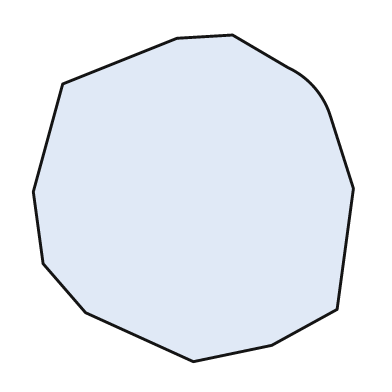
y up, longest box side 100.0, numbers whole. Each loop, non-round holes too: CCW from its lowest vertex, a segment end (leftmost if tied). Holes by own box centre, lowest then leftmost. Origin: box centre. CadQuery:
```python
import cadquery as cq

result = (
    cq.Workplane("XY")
    .moveTo(0.0, -50.0)
    .lineTo(24.0, -45.0)
    .lineTo(44.0, -34.0)
    .lineTo(49.0, 3.0)
    .lineTo(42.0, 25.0)
    .threePointArc((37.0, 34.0), (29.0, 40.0))
    .lineTo(12.0, 50.0)
    .lineTo(-5.0, 49.0)
    .lineTo(-40.0, 35.0)
    .lineTo(-49.0, 2.0)
    .lineTo(-46.0, -20.0)
    .lineTo(-33.0, -35.0)
    .close()
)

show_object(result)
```